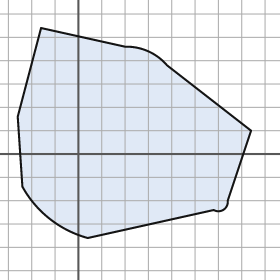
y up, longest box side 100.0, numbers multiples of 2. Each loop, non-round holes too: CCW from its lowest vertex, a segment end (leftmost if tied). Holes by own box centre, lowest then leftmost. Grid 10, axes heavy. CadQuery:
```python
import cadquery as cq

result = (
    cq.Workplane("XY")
    .moveTo(4.0, -36.0)
    .lineTo(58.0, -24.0)
    .threePointArc((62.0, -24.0), (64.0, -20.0))
    .lineTo(74.0, 10.0)
    .lineTo(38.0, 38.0)
    .threePointArc((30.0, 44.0), (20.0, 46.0))
    .lineTo(-16.0, 54.0)
    .lineTo(-26.0, 16.0)
    .lineTo(-24.0, -14.0)
    .threePointArc((-12.0, -28.0), (4.0, -36.0))
    .close()
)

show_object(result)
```